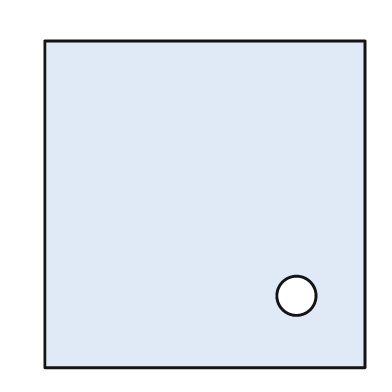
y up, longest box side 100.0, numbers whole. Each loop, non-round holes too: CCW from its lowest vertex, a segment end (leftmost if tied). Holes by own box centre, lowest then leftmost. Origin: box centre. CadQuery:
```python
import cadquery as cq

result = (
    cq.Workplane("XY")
    .moveTo(-49.0, -50.0)
    .lineTo(49.0, -50.0)
    .lineTo(49.0, 50.0)
    .lineTo(-49.0, 50.0)
    .close()
    .moveTo(28.0, -28.0)
    .circle(6.0)
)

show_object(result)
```